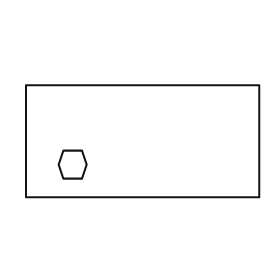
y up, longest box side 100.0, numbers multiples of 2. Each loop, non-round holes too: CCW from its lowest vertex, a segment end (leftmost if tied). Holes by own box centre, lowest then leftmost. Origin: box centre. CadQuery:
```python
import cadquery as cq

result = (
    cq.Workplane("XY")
    .moveTo(-50.0, -24.0)
    .lineTo(50.0, -24.0)
    .lineTo(50.0, 24.0)
    .lineTo(-50.0, 24.0)
    .close()
    .moveTo(-34.0, -16.0)
    .lineTo(-26.0, -16.0)
    .lineTo(-24.0, -10.0)
    .lineTo(-26.0, -4.0)
    .lineTo(-34.0, -4.0)
    .lineTo(-36.0, -10.0)
    .close()
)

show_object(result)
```